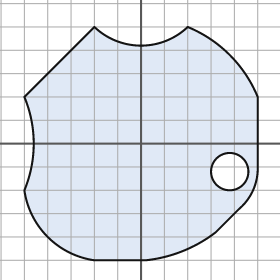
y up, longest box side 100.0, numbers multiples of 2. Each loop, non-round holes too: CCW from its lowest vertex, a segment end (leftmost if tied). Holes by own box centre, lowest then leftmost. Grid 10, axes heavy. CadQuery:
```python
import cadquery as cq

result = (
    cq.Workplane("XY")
    .moveTo(-20.0, -50.0)
    .lineTo(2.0, -50.0)
    .threePointArc((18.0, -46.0), (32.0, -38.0))
    .lineTo(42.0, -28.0)
    .threePointArc((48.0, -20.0), (50.0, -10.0))
    .lineTo(50.0, 20.0)
    .threePointArc((38.0, 38.0), (20.0, 50.0))
    .threePointArc((0.0, 42.0), (-20.0, 50.0))
    .lineTo(-50.0, 20.0)
    .threePointArc((-46.0, 0.0), (-50.0, -20.0))
    .threePointArc((-40.0, -40.0), (-20.0, -50.0))
    .close()
    .moveTo(38.0, -12.0)
    .circle(8.0)
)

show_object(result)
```